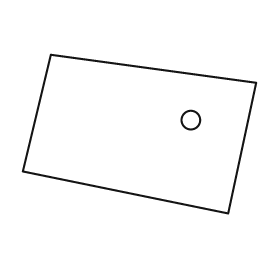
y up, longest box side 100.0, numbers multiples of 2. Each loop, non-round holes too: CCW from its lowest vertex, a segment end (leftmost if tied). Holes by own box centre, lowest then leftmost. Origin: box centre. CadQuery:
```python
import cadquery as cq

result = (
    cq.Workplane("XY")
    .moveTo(38.0, -34.0)
    .lineTo(50.0, 22.0)
    .lineTo(-38.0, 34.0)
    .lineTo(-50.0, -16.0)
    .close()
    .moveTo(22.0, 6.0)
    .circle(4.0)
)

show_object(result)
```